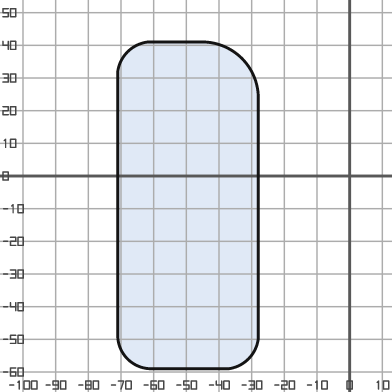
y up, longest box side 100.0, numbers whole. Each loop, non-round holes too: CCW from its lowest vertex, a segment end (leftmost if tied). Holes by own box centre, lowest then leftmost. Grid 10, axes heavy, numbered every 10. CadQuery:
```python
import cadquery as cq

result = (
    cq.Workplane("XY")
    .moveTo(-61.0, -59.0)
    .lineTo(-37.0, -59.0)
    .threePointArc((-31.0, -56.0), (-28.0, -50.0))
    .lineTo(-28.0, 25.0)
    .threePointArc((-33.0, 36.0), (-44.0, 41.0))
    .lineTo(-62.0, 41.0)
    .threePointArc((-68.0, 38.0), (-71.0, 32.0))
    .lineTo(-71.0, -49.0)
    .threePointArc((-68.0, -56.0), (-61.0, -59.0))
    .close()
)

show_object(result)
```